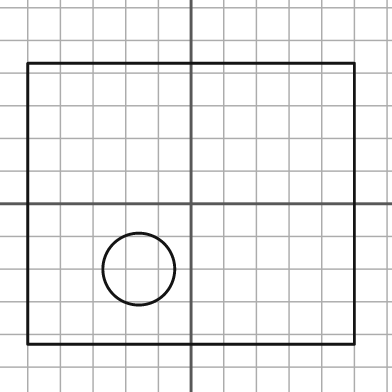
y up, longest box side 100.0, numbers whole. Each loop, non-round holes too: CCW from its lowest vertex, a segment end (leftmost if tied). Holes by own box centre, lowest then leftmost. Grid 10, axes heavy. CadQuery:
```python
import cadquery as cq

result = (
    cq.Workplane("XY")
    .moveTo(-50.0, -43.0)
    .lineTo(50.0, -43.0)
    .lineTo(50.0, 43.0)
    .lineTo(-50.0, 43.0)
    .close()
    .moveTo(-16.0, -20.0)
    .circle(11.0)
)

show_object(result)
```